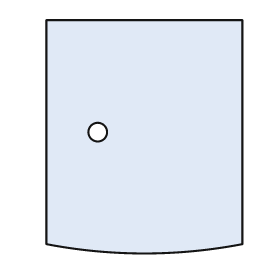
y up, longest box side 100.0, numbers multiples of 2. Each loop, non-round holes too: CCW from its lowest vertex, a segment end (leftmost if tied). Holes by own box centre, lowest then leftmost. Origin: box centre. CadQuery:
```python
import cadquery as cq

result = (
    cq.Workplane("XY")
    .moveTo(-42.0, -46.0)
    .threePointArc((0.0, -50.0), (42.0, -46.0))
    .lineTo(42.0, 50.0)
    .lineTo(-42.0, 50.0)
    .close()
    .moveTo(-20.0, 2.0)
    .circle(4.0)
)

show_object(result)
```